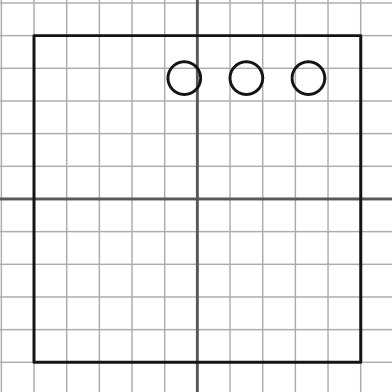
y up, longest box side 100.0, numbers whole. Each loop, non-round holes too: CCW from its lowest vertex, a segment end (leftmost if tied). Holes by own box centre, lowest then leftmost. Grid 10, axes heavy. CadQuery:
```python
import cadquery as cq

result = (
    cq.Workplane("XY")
    .moveTo(-50.0, -50.0)
    .lineTo(50.0, -50.0)
    .lineTo(50.0, 50.0)
    .lineTo(-50.0, 50.0)
    .close()
    .moveTo(-4.0, 37.0)
    .circle(5.0)
    .moveTo(15.0, 37.0)
    .circle(5.0)
    .moveTo(34.0, 37.0)
    .circle(5.0)
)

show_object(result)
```